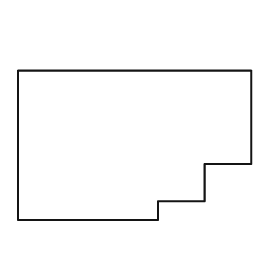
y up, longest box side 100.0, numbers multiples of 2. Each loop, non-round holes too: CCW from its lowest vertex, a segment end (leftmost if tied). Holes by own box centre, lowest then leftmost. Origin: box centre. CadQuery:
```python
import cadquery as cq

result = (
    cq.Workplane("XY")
    .moveTo(-50.0, -32.0)
    .lineTo(10.0, -32.0)
    .lineTo(10.0, -24.0)
    .lineTo(30.0, -24.0)
    .lineTo(30.0, -8.0)
    .lineTo(50.0, -8.0)
    .lineTo(50.0, 32.0)
    .lineTo(-50.0, 32.0)
    .close()
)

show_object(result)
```